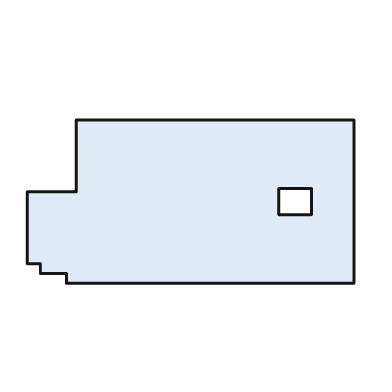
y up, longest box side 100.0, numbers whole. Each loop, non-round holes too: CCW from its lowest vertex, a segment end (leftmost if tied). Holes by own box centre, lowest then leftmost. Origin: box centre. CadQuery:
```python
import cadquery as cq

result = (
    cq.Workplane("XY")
    .moveTo(-38.0, -25.0)
    .lineTo(50.0, -25.0)
    .lineTo(50.0, 25.0)
    .lineTo(-35.0, 25.0)
    .lineTo(-35.0, 3.0)
    .lineTo(-50.0, 3.0)
    .lineTo(-50.0, -19.0)
    .lineTo(-46.0, -19.0)
    .lineTo(-46.0, -22.0)
    .lineTo(-38.0, -22.0)
    .close()
    .moveTo(27.0, -4.0)
    .lineTo(37.0, -4.0)
    .lineTo(37.0, 4.0)
    .lineTo(27.0, 4.0)
    .close()
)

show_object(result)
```